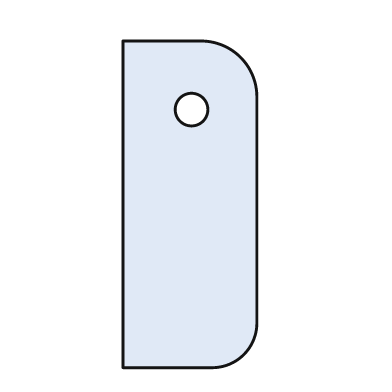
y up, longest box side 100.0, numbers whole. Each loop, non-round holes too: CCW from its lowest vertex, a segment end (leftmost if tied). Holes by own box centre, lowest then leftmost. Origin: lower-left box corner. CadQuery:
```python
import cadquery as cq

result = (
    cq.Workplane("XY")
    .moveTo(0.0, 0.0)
    .lineTo(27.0, 0.0)
    .threePointArc((37.0, 4.0), (41.0, 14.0))
    .lineTo(41.0, 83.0)
    .threePointArc((36.0, 95.0), (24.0, 100.0))
    .lineTo(0.0, 100.0)
    .close()
    .moveTo(21.0, 79.0)
    .circle(5.0)
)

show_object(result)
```